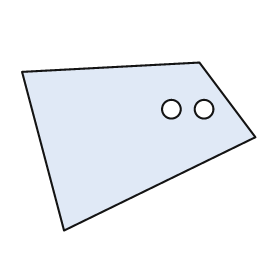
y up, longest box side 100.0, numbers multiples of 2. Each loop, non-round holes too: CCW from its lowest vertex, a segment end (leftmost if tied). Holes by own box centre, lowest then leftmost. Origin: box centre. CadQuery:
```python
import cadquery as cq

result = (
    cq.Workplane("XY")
    .moveTo(-32.0, -36.0)
    .lineTo(50.0, 4.0)
    .lineTo(26.0, 36.0)
    .lineTo(-50.0, 32.0)
    .close()
    .moveTo(14.0, 16.0)
    .circle(4.0)
    .moveTo(28.0, 16.0)
    .circle(4.0)
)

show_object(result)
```